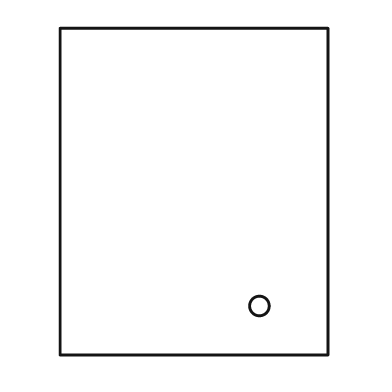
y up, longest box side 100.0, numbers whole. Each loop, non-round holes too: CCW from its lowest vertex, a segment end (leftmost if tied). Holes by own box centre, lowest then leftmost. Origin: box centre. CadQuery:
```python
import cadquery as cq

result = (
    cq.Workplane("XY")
    .moveTo(-41.0, -50.0)
    .lineTo(41.0, -50.0)
    .lineTo(41.0, 50.0)
    .lineTo(-41.0, 50.0)
    .close()
    .moveTo(20.0, -35.0)
    .circle(3.0)
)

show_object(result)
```